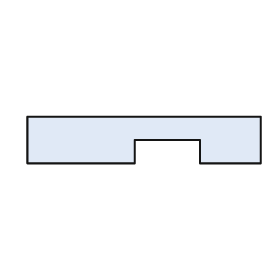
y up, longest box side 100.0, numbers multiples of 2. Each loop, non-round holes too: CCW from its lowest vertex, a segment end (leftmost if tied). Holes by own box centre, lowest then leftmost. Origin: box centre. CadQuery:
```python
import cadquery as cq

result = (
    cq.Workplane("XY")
    .moveTo(-50.0, -10.0)
    .lineTo(-4.0, -10.0)
    .lineTo(-4.0, 0.0)
    .lineTo(24.0, 0.0)
    .lineTo(24.0, -10.0)
    .lineTo(50.0, -10.0)
    .lineTo(50.0, 10.0)
    .lineTo(-50.0, 10.0)
    .close()
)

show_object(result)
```